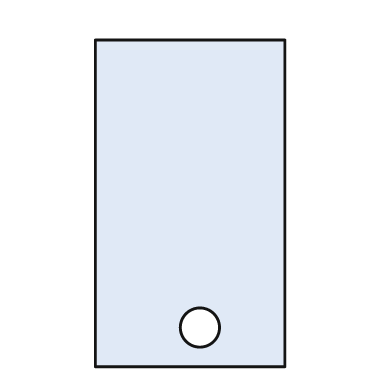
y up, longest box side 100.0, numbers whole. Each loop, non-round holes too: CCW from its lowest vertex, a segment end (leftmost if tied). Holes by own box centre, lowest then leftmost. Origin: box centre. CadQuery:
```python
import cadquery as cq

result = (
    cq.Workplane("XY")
    .moveTo(-29.0, -50.0)
    .lineTo(29.0, -50.0)
    .lineTo(29.0, 50.0)
    .lineTo(-29.0, 50.0)
    .close()
    .moveTo(3.0, -38.0)
    .circle(6.0)
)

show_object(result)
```